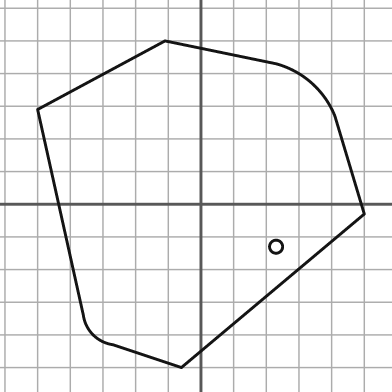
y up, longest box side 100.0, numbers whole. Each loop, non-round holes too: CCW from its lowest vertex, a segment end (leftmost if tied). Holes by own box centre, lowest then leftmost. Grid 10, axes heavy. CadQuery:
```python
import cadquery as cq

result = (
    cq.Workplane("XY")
    .moveTo(-6.0, -50.0)
    .lineTo(50.0, -3.0)
    .lineTo(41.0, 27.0)
    .threePointArc((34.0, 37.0), (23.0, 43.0))
    .lineTo(-11.0, 50.0)
    .lineTo(-50.0, 29.0)
    .lineTo(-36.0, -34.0)
    .threePointArc((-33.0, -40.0), (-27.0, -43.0))
    .close()
    .moveTo(23.0, -13.0)
    .circle(2.0)
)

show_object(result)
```